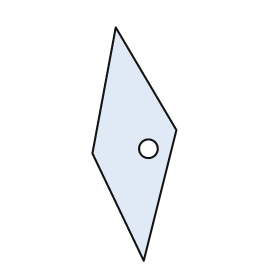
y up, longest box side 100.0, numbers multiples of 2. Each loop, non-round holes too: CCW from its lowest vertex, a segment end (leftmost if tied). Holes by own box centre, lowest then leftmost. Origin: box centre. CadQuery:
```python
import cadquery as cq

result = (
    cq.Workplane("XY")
    .moveTo(4.0, -50.0)
    .lineTo(18.0, 6.0)
    .lineTo(-8.0, 50.0)
    .lineTo(-18.0, -4.0)
    .close()
    .moveTo(6.0, -2.0)
    .circle(4.0)
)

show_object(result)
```